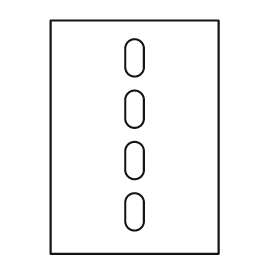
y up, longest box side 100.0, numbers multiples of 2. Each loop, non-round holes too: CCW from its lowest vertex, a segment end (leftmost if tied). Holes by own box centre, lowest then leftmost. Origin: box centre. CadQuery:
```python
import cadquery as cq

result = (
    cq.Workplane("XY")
    .moveTo(-36.0, -50.0)
    .lineTo(36.0, -50.0)
    .lineTo(36.0, 50.0)
    .lineTo(-36.0, 50.0)
    .close()
    .moveTo(-4.0, -36.0)
    .threePointArc((0.0, -40.0), (4.0, -36.0))
    .lineTo(4.0, -28.0)
    .threePointArc((0.0, -24.0), (-4.0, -28.0))
    .close()
    .moveTo(-4.0, -14.0)
    .threePointArc((0.0, -18.0), (4.0, -14.0))
    .lineTo(4.0, -6.0)
    .threePointArc((0.0, -2.0), (-4.0, -6.0))
    .close()
    .moveTo(-4.0, 8.0)
    .threePointArc((0.0, 4.0), (4.0, 8.0))
    .lineTo(4.0, 16.0)
    .threePointArc((0.0, 20.0), (-4.0, 16.0))
    .close()
    .moveTo(-4.0, 30.0)
    .threePointArc((0.0, 26.0), (4.0, 30.0))
    .lineTo(4.0, 38.0)
    .threePointArc((0.0, 42.0), (-4.0, 38.0))
    .close()
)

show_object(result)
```